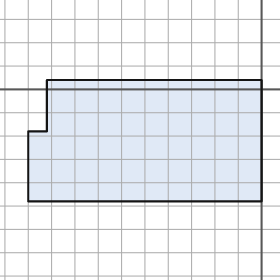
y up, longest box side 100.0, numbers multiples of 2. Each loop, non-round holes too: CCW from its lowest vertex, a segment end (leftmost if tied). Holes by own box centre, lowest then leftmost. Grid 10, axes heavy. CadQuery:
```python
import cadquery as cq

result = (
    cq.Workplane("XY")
    .moveTo(-100.0, -48.0)
    .lineTo(0.0, -48.0)
    .lineTo(0.0, 4.0)
    .lineTo(-92.0, 4.0)
    .lineTo(-92.0, -18.0)
    .lineTo(-100.0, -18.0)
    .close()
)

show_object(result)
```